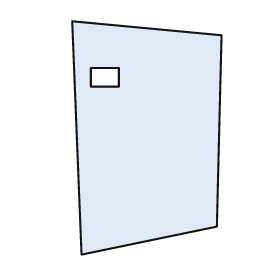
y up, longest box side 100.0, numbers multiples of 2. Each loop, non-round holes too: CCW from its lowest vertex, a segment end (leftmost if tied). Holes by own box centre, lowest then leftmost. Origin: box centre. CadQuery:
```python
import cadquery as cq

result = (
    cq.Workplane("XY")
    .moveTo(-28.0, -50.0)
    .lineTo(30.0, -38.0)
    .lineTo(32.0, 44.0)
    .lineTo(-32.0, 50.0)
    .close()
    .moveTo(-24.0, 22.0)
    .lineTo(-12.0, 22.0)
    .lineTo(-12.0, 30.0)
    .lineTo(-24.0, 30.0)
    .close()
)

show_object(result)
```